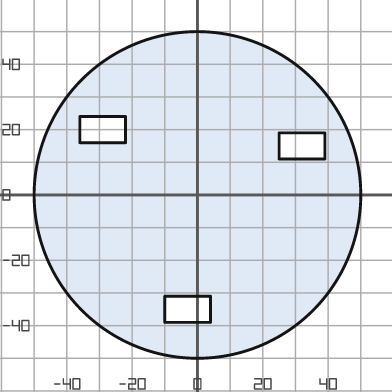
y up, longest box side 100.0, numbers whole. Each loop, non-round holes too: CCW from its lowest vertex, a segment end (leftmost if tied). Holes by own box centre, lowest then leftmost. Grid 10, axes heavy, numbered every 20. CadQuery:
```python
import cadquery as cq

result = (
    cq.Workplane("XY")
    .moveTo(0.0, 0.0)
    .circle(50.0)
    .moveTo(-10.0, -39.0)
    .lineTo(4.0, -39.0)
    .lineTo(4.0, -31.0)
    .lineTo(-10.0, -31.0)
    .close()
    .moveTo(25.0, 11.0)
    .lineTo(39.0, 11.0)
    .lineTo(39.0, 19.0)
    .lineTo(25.0, 19.0)
    .close()
    .moveTo(-36.0, 16.0)
    .lineTo(-22.0, 16.0)
    .lineTo(-22.0, 24.0)
    .lineTo(-36.0, 24.0)
    .close()
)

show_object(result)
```